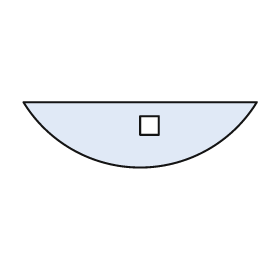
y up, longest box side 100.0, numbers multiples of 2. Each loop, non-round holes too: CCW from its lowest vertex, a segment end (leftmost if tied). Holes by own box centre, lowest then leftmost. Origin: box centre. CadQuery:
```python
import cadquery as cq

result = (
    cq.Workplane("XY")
    .moveTo(-50.0, 14.0)
    .threePointArc((0.0, -14.0), (50.0, 14.0))
    .close()
    .moveTo(0.0, 0.0)
    .lineTo(8.0, 0.0)
    .lineTo(8.0, 8.0)
    .lineTo(0.0, 8.0)
    .close()
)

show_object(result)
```